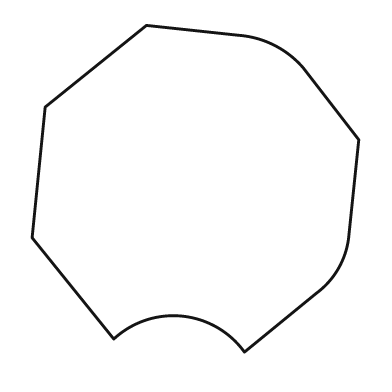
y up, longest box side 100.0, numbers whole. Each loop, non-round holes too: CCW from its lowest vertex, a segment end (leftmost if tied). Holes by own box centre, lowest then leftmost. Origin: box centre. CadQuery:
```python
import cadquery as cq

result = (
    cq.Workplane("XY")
    .moveTo(15.0, -50.0)
    .lineTo(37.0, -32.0)
    .threePointArc((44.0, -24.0), (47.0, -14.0))
    .lineTo(50.0, 15.0)
    .lineTo(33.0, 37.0)
    .threePointArc((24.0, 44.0), (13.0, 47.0))
    .lineTo(-15.0, 50.0)
    .lineTo(-46.0, 25.0)
    .lineTo(-50.0, -15.0)
    .lineTo(-25.0, -46.0)
    .threePointArc((-4.0, -39.0), (15.0, -50.0))
    .close()
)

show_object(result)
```